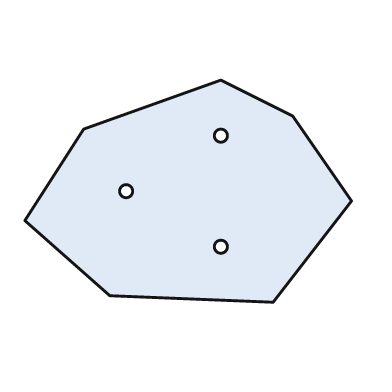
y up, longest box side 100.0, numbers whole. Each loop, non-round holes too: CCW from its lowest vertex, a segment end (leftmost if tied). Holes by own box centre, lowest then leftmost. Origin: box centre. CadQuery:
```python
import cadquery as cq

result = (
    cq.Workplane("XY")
    .moveTo(26.0, -34.0)
    .lineTo(50.0, -3.0)
    .lineTo(32.0, 23.0)
    .lineTo(10.0, 34.0)
    .lineTo(-32.0, 19.0)
    .lineTo(-50.0, -9.0)
    .lineTo(-24.0, -32.0)
    .close()
    .moveTo(10.0, -17.0)
    .circle(2.0)
    .moveTo(-19.0, 0.0)
    .circle(2.0)
    .moveTo(10.0, 17.0)
    .circle(2.0)
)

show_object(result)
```